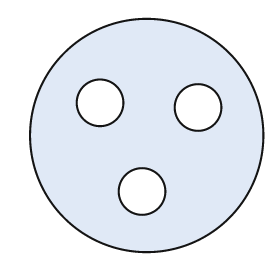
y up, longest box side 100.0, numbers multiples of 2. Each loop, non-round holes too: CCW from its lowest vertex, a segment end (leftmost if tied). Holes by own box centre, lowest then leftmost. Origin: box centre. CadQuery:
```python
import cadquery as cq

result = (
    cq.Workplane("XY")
    .moveTo(0.0, 0.0)
    .circle(50.0)
    .moveTo(-2.0, -24.0)
    .circle(10.0)
    .moveTo(22.0, 12.0)
    .circle(10.0)
    .moveTo(-20.0, 14.0)
    .circle(10.0)
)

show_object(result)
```